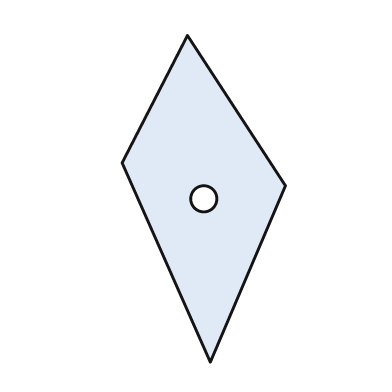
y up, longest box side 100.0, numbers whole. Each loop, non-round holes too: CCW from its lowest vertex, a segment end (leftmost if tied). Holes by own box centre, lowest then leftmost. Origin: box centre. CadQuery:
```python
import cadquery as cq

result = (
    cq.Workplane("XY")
    .moveTo(2.0, -50.0)
    .lineTo(25.0, 4.0)
    .lineTo(-5.0, 50.0)
    .lineTo(-25.0, 11.0)
    .close()
    .moveTo(0.0, 0.0)
    .circle(4.0)
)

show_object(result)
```